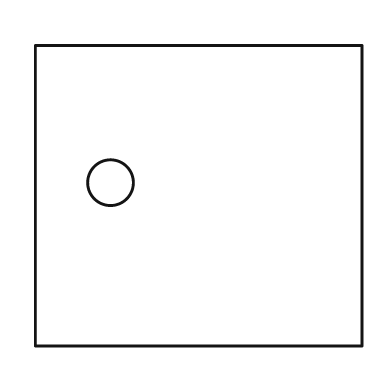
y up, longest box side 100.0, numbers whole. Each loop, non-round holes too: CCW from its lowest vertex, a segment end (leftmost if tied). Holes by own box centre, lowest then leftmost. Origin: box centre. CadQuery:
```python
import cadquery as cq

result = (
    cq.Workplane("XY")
    .moveTo(-50.0, -46.0)
    .lineTo(50.0, -46.0)
    .lineTo(50.0, 46.0)
    .lineTo(-50.0, 46.0)
    .close()
    .moveTo(-27.0, 4.0)
    .circle(7.0)
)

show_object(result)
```